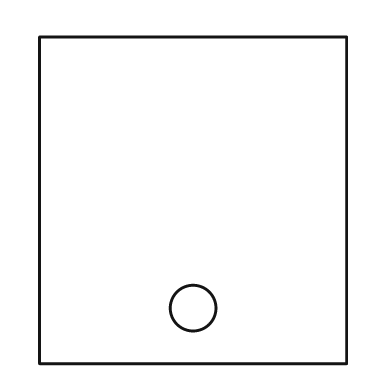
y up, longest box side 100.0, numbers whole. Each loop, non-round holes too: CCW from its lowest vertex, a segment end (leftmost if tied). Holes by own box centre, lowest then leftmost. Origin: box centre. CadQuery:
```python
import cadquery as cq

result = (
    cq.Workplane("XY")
    .moveTo(-47.0, -50.0)
    .lineTo(47.0, -50.0)
    .lineTo(47.0, 50.0)
    .lineTo(-47.0, 50.0)
    .close()
    .moveTo(0.0, -33.0)
    .circle(7.0)
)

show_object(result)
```